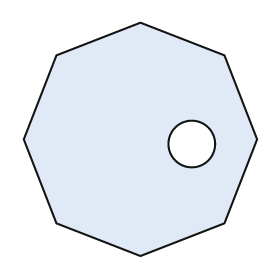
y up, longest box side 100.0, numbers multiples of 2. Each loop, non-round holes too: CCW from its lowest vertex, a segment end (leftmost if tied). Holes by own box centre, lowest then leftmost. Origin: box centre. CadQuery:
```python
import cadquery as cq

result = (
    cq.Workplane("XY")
    .moveTo(0.0, -50.0)
    .lineTo(36.0, -36.0)
    .lineTo(50.0, 0.0)
    .lineTo(36.0, 36.0)
    .lineTo(0.0, 50.0)
    .lineTo(-36.0, 36.0)
    .lineTo(-50.0, 0.0)
    .lineTo(-36.0, -36.0)
    .close()
    .moveTo(22.0, -2.0)
    .circle(10.0)
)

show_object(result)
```